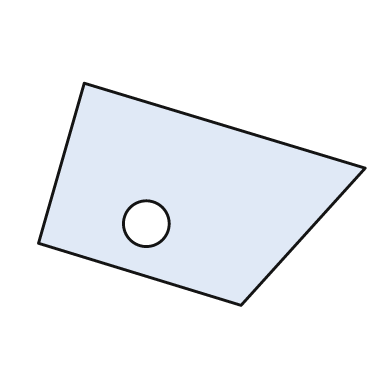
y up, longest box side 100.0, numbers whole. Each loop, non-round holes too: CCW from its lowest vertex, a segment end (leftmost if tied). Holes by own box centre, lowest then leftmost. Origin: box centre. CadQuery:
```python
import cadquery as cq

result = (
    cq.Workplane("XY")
    .moveTo(12.0, -34.0)
    .lineTo(50.0, 8.0)
    .lineTo(-36.0, 34.0)
    .lineTo(-50.0, -15.0)
    .close()
    .moveTo(-17.0, -9.0)
    .circle(7.0)
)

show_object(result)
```